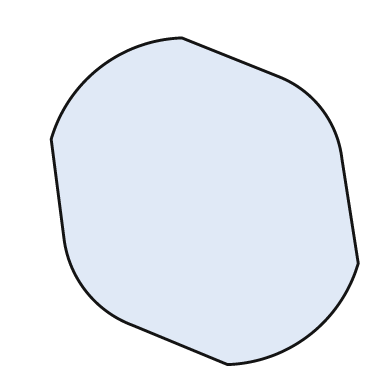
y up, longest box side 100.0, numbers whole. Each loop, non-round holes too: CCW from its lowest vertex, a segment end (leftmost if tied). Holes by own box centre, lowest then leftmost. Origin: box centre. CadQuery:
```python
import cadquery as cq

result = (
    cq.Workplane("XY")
    .moveTo(7.0, -50.0)
    .threePointArc((32.0, -41.0), (47.0, -19.0))
    .lineTo(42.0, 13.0)
    .threePointArc((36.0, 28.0), (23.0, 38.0))
    .lineTo(-7.0, 50.0)
    .threePointArc((-32.0, 41.0), (-47.0, 19.0))
    .lineTo(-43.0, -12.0)
    .threePointArc((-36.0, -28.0), (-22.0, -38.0))
    .close()
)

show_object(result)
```